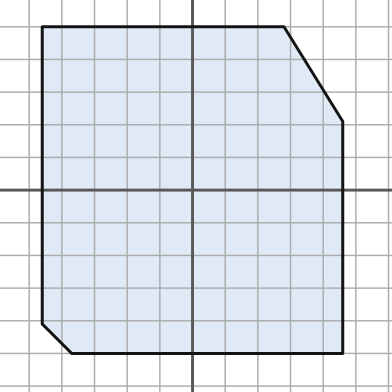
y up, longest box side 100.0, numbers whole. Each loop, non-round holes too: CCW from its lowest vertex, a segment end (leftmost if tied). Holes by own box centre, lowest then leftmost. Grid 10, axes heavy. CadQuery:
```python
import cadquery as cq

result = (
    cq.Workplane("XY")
    .moveTo(-37.0, -50.0)
    .lineTo(46.0, -50.0)
    .lineTo(46.0, 21.0)
    .lineTo(28.0, 50.0)
    .lineTo(-46.0, 50.0)
    .lineTo(-46.0, -41.0)
    .close()
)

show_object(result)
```